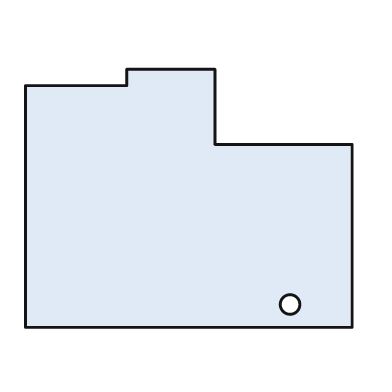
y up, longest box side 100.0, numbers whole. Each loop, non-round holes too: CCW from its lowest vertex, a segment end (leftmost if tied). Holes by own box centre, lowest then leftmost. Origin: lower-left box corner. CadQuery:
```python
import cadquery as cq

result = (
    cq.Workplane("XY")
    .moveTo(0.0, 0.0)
    .lineTo(100.0, 0.0)
    .lineTo(100.0, 56.0)
    .lineTo(58.0, 56.0)
    .lineTo(58.0, 79.0)
    .lineTo(31.0, 79.0)
    .lineTo(31.0, 74.0)
    .lineTo(0.0, 74.0)
    .close()
    .moveTo(81.0, 7.0)
    .circle(3.0)
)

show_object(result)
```